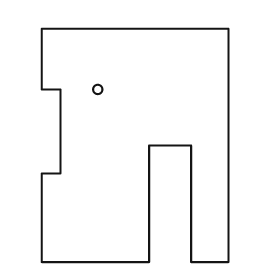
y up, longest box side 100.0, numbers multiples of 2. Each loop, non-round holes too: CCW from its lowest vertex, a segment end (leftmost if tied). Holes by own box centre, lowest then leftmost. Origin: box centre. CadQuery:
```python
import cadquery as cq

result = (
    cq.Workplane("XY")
    .moveTo(-40.0, -50.0)
    .lineTo(6.0, -50.0)
    .lineTo(6.0, 0.0)
    .lineTo(24.0, 0.0)
    .lineTo(24.0, -50.0)
    .lineTo(40.0, -50.0)
    .lineTo(40.0, 50.0)
    .lineTo(-40.0, 50.0)
    .lineTo(-40.0, 24.0)
    .lineTo(-32.0, 24.0)
    .lineTo(-32.0, -12.0)
    .lineTo(-40.0, -12.0)
    .close()
    .moveTo(-16.0, 24.0)
    .circle(2.0)
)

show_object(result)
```